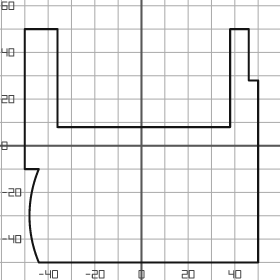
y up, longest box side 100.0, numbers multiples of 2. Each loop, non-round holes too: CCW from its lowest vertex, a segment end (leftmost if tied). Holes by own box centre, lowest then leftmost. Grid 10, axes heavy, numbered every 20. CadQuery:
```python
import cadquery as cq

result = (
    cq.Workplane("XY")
    .moveTo(-44.0, -50.0)
    .lineTo(50.0, -50.0)
    .lineTo(50.0, 28.0)
    .lineTo(46.0, 28.0)
    .lineTo(46.0, 50.0)
    .lineTo(38.0, 50.0)
    .lineTo(38.0, 8.0)
    .lineTo(-36.0, 8.0)
    .lineTo(-36.0, 50.0)
    .lineTo(-50.0, 50.0)
    .lineTo(-50.0, -10.0)
    .lineTo(-44.0, -10.0)
    .threePointArc((-48.0, -30.0), (-44.0, -50.0))
    .close()
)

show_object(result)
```